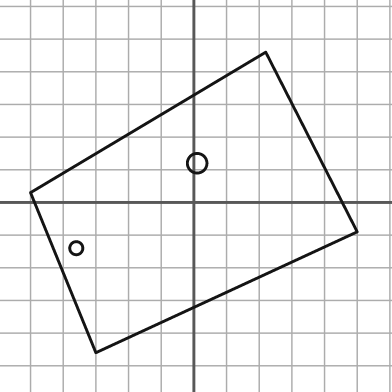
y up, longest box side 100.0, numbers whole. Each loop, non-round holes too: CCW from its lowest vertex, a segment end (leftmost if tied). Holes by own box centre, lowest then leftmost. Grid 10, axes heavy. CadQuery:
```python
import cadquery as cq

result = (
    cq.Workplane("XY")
    .moveTo(-30.0, -46.0)
    .lineTo(50.0, -9.0)
    .lineTo(22.0, 46.0)
    .lineTo(-50.0, 3.0)
    .close()
    .moveTo(-36.0, -14.0)
    .circle(2.0)
    .moveTo(1.0, 12.0)
    .circle(3.0)
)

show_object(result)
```